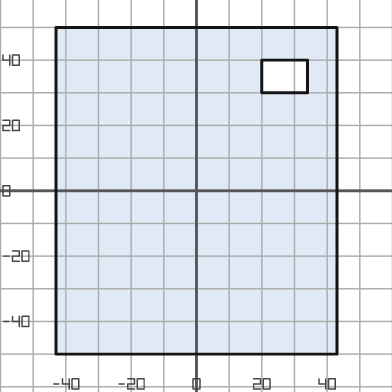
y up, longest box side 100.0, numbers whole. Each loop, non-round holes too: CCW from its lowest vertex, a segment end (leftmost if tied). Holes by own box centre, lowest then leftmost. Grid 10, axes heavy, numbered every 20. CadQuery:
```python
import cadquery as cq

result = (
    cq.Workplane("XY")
    .moveTo(-43.0, -50.0)
    .lineTo(43.0, -50.0)
    .lineTo(43.0, 50.0)
    .lineTo(-43.0, 50.0)
    .close()
    .moveTo(20.0, 30.0)
    .lineTo(34.0, 30.0)
    .lineTo(34.0, 40.0)
    .lineTo(20.0, 40.0)
    .close()
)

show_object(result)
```